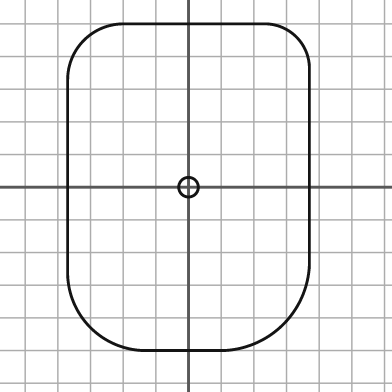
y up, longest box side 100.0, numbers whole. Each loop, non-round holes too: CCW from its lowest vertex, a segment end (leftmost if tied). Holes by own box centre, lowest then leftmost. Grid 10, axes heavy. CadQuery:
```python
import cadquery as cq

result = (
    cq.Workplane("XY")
    .moveTo(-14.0, -50.0)
    .lineTo(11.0, -50.0)
    .threePointArc((29.0, -42.0), (37.0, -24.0))
    .lineTo(37.0, 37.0)
    .threePointArc((33.0, 46.0), (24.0, 50.0))
    .lineTo(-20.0, 50.0)
    .threePointArc((-32.0, 45.0), (-37.0, 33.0))
    .lineTo(-37.0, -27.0)
    .threePointArc((-30.0, -43.0), (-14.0, -50.0))
    .close()
    .moveTo(0.0, 0.0)
    .circle(3.0)
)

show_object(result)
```